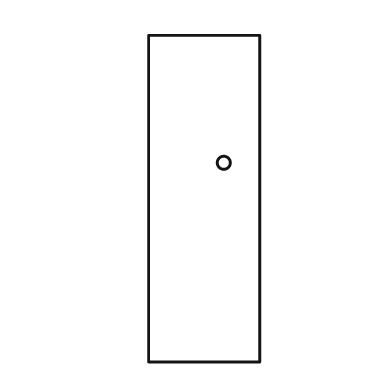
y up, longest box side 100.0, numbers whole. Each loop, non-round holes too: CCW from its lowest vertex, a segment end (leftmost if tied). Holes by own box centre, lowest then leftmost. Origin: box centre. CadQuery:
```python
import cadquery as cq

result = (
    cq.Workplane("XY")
    .moveTo(-17.0, -50.0)
    .lineTo(17.0, -50.0)
    .lineTo(17.0, 50.0)
    .lineTo(-17.0, 50.0)
    .close()
    .moveTo(6.0, 11.0)
    .circle(2.0)
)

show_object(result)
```